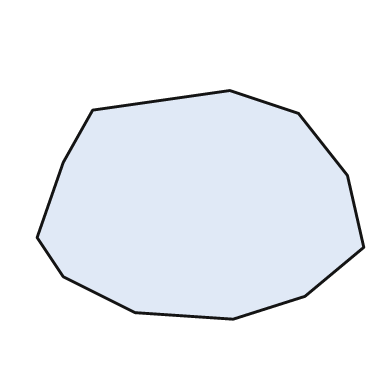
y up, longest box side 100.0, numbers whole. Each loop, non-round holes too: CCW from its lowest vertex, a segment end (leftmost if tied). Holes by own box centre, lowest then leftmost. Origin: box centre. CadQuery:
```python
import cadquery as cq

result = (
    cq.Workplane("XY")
    .moveTo(10.0, -35.0)
    .lineTo(32.0, -28.0)
    .lineTo(50.0, -13.0)
    .lineTo(45.0, 9.0)
    .lineTo(30.0, 28.0)
    .lineTo(9.0, 35.0)
    .lineTo(-33.0, 29.0)
    .lineTo(-42.0, 13.0)
    .lineTo(-50.0, -10.0)
    .lineTo(-42.0, -22.0)
    .lineTo(-20.0, -33.0)
    .close()
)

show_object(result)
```